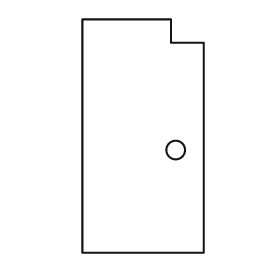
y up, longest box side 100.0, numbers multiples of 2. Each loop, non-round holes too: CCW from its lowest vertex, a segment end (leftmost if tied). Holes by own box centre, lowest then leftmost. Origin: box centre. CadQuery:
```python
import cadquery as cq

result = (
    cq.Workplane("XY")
    .moveTo(-26.0, -50.0)
    .lineTo(26.0, -50.0)
    .lineTo(26.0, 40.0)
    .lineTo(12.0, 40.0)
    .lineTo(12.0, 50.0)
    .lineTo(-26.0, 50.0)
    .close()
    .moveTo(14.0, -6.0)
    .circle(4.0)
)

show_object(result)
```